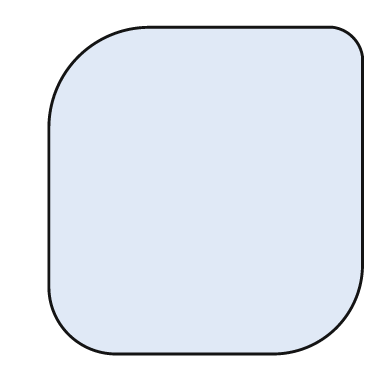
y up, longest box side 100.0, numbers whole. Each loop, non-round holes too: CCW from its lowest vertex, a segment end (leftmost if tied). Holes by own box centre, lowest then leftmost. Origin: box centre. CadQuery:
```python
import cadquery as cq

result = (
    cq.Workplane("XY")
    .moveTo(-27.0, -50.0)
    .lineTo(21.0, -50.0)
    .threePointArc((40.0, -42.0), (48.0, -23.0))
    .lineTo(48.0, 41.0)
    .threePointArc((45.0, 47.0), (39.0, 50.0))
    .lineTo(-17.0, 50.0)
    .threePointArc((-39.0, 41.0), (-48.0, 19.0))
    .lineTo(-48.0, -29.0)
    .threePointArc((-42.0, -44.0), (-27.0, -50.0))
    .close()
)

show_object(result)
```